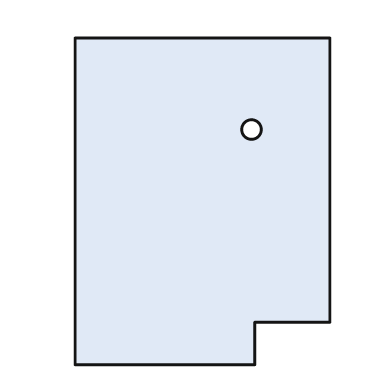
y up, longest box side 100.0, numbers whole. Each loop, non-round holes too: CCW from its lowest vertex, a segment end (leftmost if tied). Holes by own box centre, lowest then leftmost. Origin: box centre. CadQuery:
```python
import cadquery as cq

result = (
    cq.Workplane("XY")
    .moveTo(-39.0, -50.0)
    .lineTo(16.0, -50.0)
    .lineTo(16.0, -37.0)
    .lineTo(39.0, -37.0)
    .lineTo(39.0, 50.0)
    .lineTo(-39.0, 50.0)
    .close()
    .moveTo(15.0, 22.0)
    .circle(3.0)
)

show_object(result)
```